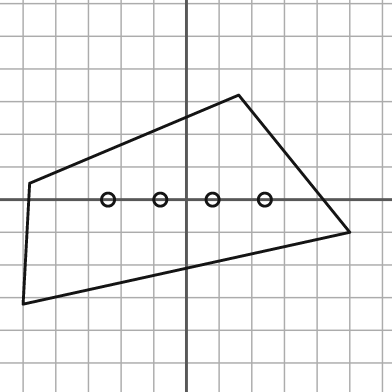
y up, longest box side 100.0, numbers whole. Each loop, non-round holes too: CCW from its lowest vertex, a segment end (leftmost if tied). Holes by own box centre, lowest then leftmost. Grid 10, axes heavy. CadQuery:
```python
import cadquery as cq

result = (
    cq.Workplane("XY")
    .moveTo(-50.0, -32.0)
    .lineTo(50.0, -10.0)
    .lineTo(16.0, 32.0)
    .lineTo(-48.0, 5.0)
    .close()
    .moveTo(-24.0, 0.0)
    .circle(2.0)
    .moveTo(-8.0, 0.0)
    .circle(2.0)
    .moveTo(8.0, 0.0)
    .circle(2.0)
    .moveTo(24.0, 0.0)
    .circle(2.0)
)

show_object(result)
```